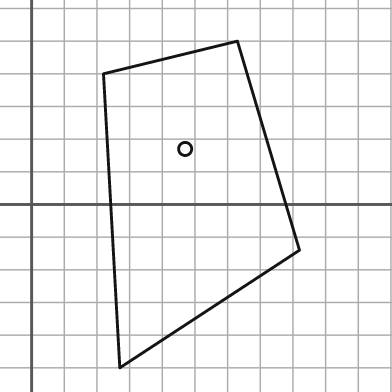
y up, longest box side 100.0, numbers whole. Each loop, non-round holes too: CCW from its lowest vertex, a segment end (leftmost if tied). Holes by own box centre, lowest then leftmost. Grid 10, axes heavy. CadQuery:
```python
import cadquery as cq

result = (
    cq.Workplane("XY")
    .moveTo(27.0, -50.0)
    .lineTo(82.0, -14.0)
    .lineTo(63.0, 50.0)
    .lineTo(22.0, 40.0)
    .close()
    .moveTo(47.0, 17.0)
    .circle(2.0)
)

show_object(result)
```